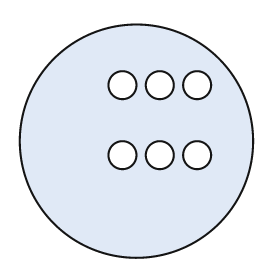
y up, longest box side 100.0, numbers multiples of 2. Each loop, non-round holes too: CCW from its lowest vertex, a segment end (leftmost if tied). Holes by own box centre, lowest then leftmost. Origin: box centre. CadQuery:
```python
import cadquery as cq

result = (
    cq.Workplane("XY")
    .moveTo(0.0, 0.0)
    .circle(50.0)
    .moveTo(-6.0, -6.0)
    .circle(6.0)
    .moveTo(10.0, -6.0)
    .circle(6.0)
    .moveTo(26.0, -6.0)
    .circle(6.0)
    .moveTo(-6.0, 24.0)
    .circle(6.0)
    .moveTo(10.0, 24.0)
    .circle(6.0)
    .moveTo(26.0, 24.0)
    .circle(6.0)
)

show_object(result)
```